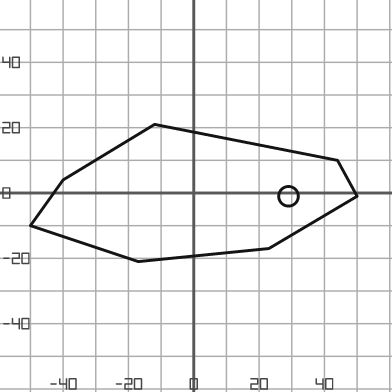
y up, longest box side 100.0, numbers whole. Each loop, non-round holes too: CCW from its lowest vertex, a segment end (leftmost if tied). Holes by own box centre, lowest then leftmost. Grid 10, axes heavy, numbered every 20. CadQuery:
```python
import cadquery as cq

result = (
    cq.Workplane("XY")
    .moveTo(-17.0, -21.0)
    .lineTo(23.0, -17.0)
    .lineTo(50.0, -1.0)
    .lineTo(44.0, 10.0)
    .lineTo(-12.0, 21.0)
    .lineTo(-40.0, 4.0)
    .lineTo(-50.0, -10.0)
    .close()
    .moveTo(29.0, -1.0)
    .circle(3.0)
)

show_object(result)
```